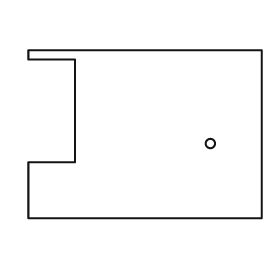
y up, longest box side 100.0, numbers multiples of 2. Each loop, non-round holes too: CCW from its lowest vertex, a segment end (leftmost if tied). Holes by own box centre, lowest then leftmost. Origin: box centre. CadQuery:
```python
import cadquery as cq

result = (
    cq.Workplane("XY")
    .moveTo(-50.0, -36.0)
    .lineTo(50.0, -36.0)
    .lineTo(50.0, 36.0)
    .lineTo(-50.0, 36.0)
    .lineTo(-50.0, 32.0)
    .lineTo(-30.0, 32.0)
    .lineTo(-30.0, -12.0)
    .lineTo(-50.0, -12.0)
    .close()
    .moveTo(28.0, -4.0)
    .circle(2.0)
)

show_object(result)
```